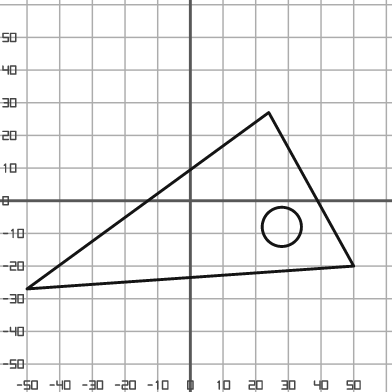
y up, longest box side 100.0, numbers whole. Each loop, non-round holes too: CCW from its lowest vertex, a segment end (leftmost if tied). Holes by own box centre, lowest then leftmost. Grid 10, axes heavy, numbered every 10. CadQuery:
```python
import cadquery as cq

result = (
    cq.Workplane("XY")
    .moveTo(-50.0, -27.0)
    .lineTo(50.0, -20.0)
    .lineTo(24.0, 27.0)
    .close()
    .moveTo(28.0, -8.0)
    .circle(6.0)
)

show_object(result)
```